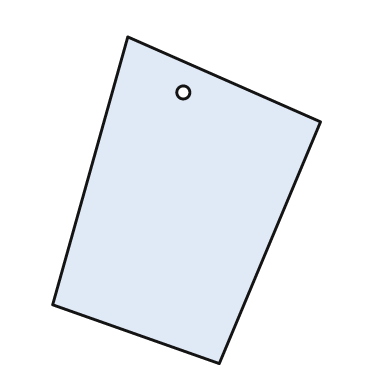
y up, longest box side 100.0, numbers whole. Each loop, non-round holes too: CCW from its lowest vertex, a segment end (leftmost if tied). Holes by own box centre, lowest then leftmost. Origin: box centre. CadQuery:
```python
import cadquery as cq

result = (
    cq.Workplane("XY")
    .moveTo(10.0, -50.0)
    .lineTo(41.0, 24.0)
    .lineTo(-18.0, 50.0)
    .lineTo(-41.0, -32.0)
    .close()
    .moveTo(-1.0, 33.0)
    .circle(2.0)
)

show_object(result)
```